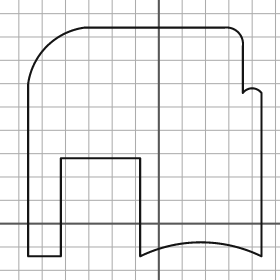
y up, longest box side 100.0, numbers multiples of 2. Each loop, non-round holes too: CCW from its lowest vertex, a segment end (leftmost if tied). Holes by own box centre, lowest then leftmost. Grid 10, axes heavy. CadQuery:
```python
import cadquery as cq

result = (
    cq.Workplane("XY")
    .moveTo(-56.0, -14.0)
    .lineTo(-42.0, -14.0)
    .lineTo(-42.0, 28.0)
    .lineTo(-8.0, 28.0)
    .lineTo(-8.0, -14.0)
    .threePointArc((18.0, -8.0), (44.0, -14.0))
    .lineTo(44.0, 56.0)
    .threePointArc((40.0, 58.0), (36.0, 56.0))
    .lineTo(36.0, 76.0)
    .threePointArc((34.0, 82.0), (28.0, 84.0))
    .lineTo(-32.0, 84.0)
    .threePointArc((-48.0, 76.0), (-56.0, 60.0))
    .close()
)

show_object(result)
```